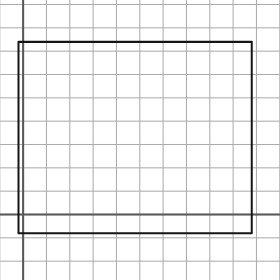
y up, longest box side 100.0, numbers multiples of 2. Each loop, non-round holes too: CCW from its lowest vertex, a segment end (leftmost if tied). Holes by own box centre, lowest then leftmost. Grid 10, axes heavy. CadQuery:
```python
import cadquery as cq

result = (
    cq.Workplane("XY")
    .moveTo(-2.0, -8.0)
    .lineTo(98.0, -8.0)
    .lineTo(98.0, 74.0)
    .lineTo(-2.0, 74.0)
    .close()
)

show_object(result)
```